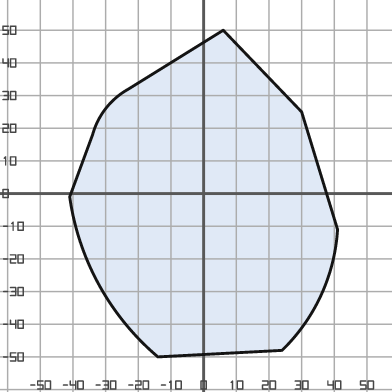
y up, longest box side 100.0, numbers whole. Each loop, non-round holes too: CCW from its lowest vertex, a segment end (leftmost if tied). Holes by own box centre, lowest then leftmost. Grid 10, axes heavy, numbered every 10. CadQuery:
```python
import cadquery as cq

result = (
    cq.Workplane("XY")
    .moveTo(-14.0, -50.0)
    .lineTo(24.0, -48.0)
    .threePointArc((36.0, -31.0), (41.0, -11.0))
    .lineTo(30.0, 25.0)
    .lineTo(6.0, 50.0)
    .lineTo(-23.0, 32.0)
    .threePointArc((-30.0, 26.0), (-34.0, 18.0))
    .lineTo(-41.0, -1.0)
    .threePointArc((-32.0, -28.0), (-14.0, -50.0))
    .close()
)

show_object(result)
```